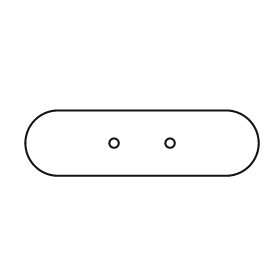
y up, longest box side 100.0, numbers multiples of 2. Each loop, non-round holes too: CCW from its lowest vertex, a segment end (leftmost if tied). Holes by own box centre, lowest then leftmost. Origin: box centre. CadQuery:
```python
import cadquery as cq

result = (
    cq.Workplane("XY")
    .moveTo(-36.0, -14.0)
    .lineTo(36.0, -14.0)
    .threePointArc((50.0, 0.0), (36.0, 14.0))
    .lineTo(-36.0, 14.0)
    .threePointArc((-50.0, 0.0), (-36.0, -14.0))
    .close()
    .moveTo(-12.0, 0.0)
    .circle(2.0)
    .moveTo(12.0, 0.0)
    .circle(2.0)
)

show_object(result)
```